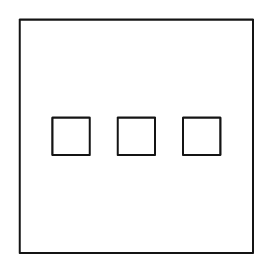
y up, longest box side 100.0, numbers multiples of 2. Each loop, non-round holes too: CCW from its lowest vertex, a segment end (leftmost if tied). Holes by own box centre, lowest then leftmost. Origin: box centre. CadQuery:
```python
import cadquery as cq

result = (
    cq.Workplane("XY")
    .moveTo(-50.0, -50.0)
    .lineTo(50.0, -50.0)
    .lineTo(50.0, 50.0)
    .lineTo(-50.0, 50.0)
    .close()
    .moveTo(-36.0, -8.0)
    .lineTo(-20.0, -8.0)
    .lineTo(-20.0, 8.0)
    .lineTo(-36.0, 8.0)
    .close()
    .moveTo(-8.0, -8.0)
    .lineTo(8.0, -8.0)
    .lineTo(8.0, 8.0)
    .lineTo(-8.0, 8.0)
    .close()
    .moveTo(20.0, -8.0)
    .lineTo(36.0, -8.0)
    .lineTo(36.0, 8.0)
    .lineTo(20.0, 8.0)
    .close()
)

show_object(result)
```